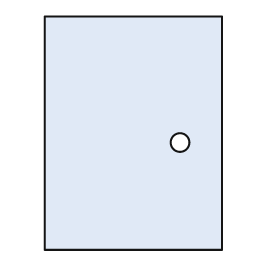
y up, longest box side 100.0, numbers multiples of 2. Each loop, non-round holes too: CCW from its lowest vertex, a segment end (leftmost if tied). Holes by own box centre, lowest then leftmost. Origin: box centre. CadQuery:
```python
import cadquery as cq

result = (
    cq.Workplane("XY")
    .moveTo(-38.0, -50.0)
    .lineTo(38.0, -50.0)
    .lineTo(38.0, 50.0)
    .lineTo(-38.0, 50.0)
    .close()
    .moveTo(20.0, -4.0)
    .circle(4.0)
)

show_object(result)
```